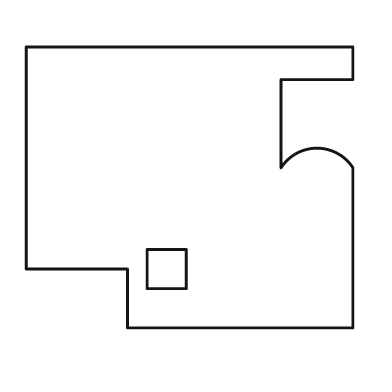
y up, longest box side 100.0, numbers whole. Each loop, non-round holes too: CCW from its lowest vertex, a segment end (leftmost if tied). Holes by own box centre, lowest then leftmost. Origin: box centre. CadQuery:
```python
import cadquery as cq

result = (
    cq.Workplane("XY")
    .moveTo(-19.0, -43.0)
    .lineTo(50.0, -43.0)
    .lineTo(50.0, 6.0)
    .threePointArc((39.0, 12.0), (28.0, 6.0))
    .lineTo(28.0, 33.0)
    .lineTo(50.0, 33.0)
    .lineTo(50.0, 43.0)
    .lineTo(-50.0, 43.0)
    .lineTo(-50.0, -25.0)
    .lineTo(-19.0, -25.0)
    .close()
    .moveTo(-13.0, -31.0)
    .lineTo(-1.0, -31.0)
    .lineTo(-1.0, -19.0)
    .lineTo(-13.0, -19.0)
    .close()
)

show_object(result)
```